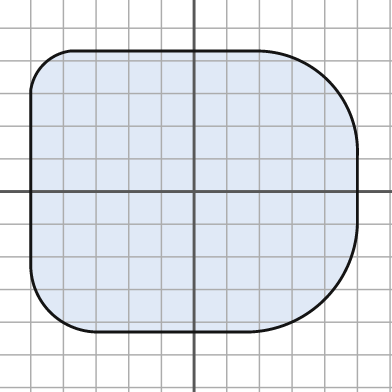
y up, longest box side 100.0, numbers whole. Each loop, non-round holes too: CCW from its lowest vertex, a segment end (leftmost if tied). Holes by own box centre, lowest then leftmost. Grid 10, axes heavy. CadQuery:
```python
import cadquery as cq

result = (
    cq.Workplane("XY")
    .moveTo(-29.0, -43.0)
    .lineTo(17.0, -43.0)
    .threePointArc((40.0, -33.0), (50.0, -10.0))
    .lineTo(50.0, 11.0)
    .threePointArc((41.0, 34.0), (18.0, 43.0))
    .lineTo(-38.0, 43.0)
    .threePointArc((-46.0, 39.0), (-50.0, 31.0))
    .lineTo(-50.0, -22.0)
    .threePointArc((-44.0, -37.0), (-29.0, -43.0))
    .close()
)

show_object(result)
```